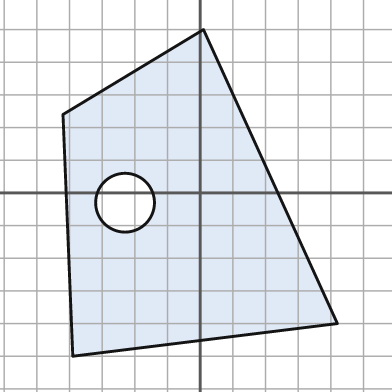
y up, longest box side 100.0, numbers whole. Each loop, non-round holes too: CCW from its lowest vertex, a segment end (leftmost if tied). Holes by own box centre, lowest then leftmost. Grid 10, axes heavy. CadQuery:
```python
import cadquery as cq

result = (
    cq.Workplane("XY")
    .moveTo(-39.0, -50.0)
    .lineTo(42.0, -40.0)
    .lineTo(1.0, 50.0)
    .lineTo(-42.0, 24.0)
    .close()
    .moveTo(-23.0, -3.0)
    .circle(9.0)
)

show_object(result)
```